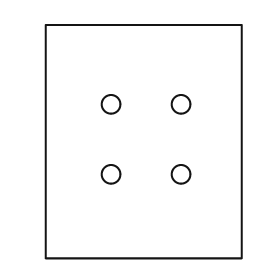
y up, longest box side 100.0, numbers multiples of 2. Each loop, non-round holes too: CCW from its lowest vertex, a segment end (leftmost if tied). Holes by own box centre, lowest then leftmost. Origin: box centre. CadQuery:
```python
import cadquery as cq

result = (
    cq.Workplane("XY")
    .moveTo(-42.0, -50.0)
    .lineTo(42.0, -50.0)
    .lineTo(42.0, 50.0)
    .lineTo(-42.0, 50.0)
    .close()
    .moveTo(-14.0, -14.0)
    .circle(4.0)
    .moveTo(16.0, -14.0)
    .circle(4.0)
    .moveTo(-14.0, 16.0)
    .circle(4.0)
    .moveTo(16.0, 16.0)
    .circle(4.0)
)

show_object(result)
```